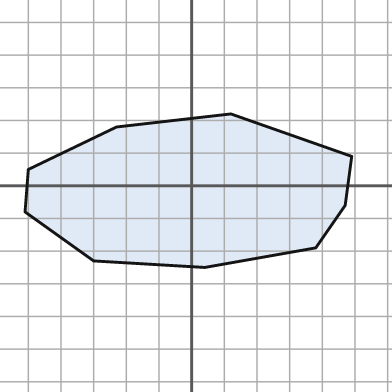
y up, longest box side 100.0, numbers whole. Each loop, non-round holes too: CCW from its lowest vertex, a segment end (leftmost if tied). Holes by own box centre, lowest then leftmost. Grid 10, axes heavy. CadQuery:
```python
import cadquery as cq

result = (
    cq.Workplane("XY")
    .moveTo(4.0, -25.0)
    .lineTo(38.0, -19.0)
    .lineTo(47.0, -6.0)
    .lineTo(49.0, 9.0)
    .lineTo(12.0, 22.0)
    .lineTo(-23.0, 18.0)
    .lineTo(-50.0, 5.0)
    .lineTo(-51.0, -8.0)
    .lineTo(-30.0, -23.0)
    .close()
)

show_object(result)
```